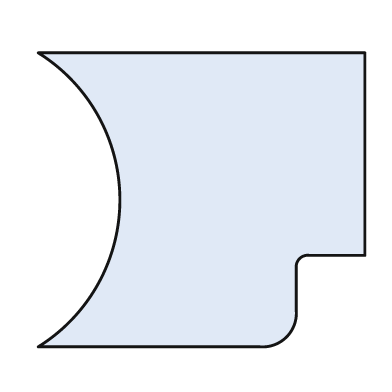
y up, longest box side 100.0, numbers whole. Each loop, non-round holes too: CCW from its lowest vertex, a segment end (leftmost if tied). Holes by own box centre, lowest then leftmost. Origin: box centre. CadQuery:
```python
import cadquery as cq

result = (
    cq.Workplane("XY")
    .moveTo(-50.0, -45.0)
    .lineTo(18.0, -45.0)
    .threePointArc((26.0, -42.0), (29.0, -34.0))
    .lineTo(29.0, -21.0)
    .threePointArc((30.0, -18.0), (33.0, -17.0))
    .lineTo(50.0, -17.0)
    .lineTo(50.0, 45.0)
    .lineTo(-50.0, 45.0)
    .threePointArc((-25.0, 0.0), (-50.0, -45.0))
    .close()
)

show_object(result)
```